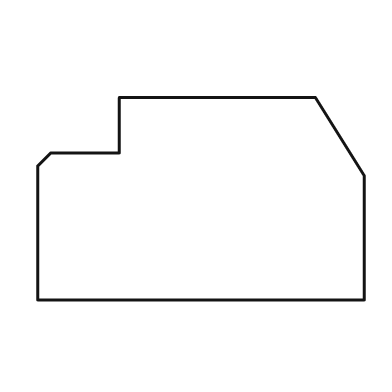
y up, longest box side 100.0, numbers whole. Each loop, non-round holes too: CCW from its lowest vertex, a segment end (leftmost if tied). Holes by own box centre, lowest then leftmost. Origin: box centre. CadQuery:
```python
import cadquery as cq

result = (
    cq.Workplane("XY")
    .moveTo(-50.0, -31.0)
    .lineTo(50.0, -31.0)
    .lineTo(50.0, 7.0)
    .lineTo(35.0, 31.0)
    .lineTo(-25.0, 31.0)
    .lineTo(-25.0, 14.0)
    .lineTo(-46.0, 14.0)
    .lineTo(-50.0, 10.0)
    .close()
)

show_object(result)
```